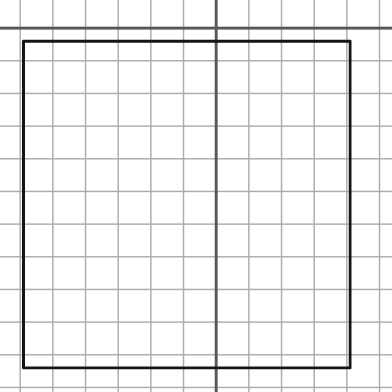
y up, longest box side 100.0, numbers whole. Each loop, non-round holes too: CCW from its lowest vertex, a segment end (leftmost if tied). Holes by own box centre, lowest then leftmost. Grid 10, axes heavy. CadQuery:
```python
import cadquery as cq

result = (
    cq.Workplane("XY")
    .moveTo(-59.0, -104.0)
    .lineTo(41.0, -104.0)
    .lineTo(41.0, -4.0)
    .lineTo(-59.0, -4.0)
    .close()
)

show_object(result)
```